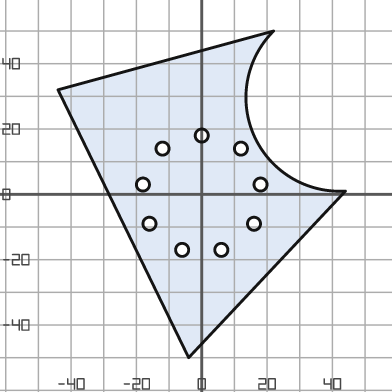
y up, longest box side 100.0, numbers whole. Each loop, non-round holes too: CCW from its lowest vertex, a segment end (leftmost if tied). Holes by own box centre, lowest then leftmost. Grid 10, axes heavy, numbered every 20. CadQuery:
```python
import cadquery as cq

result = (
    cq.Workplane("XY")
    .moveTo(-4.0, -50.0)
    .lineTo(44.0, 1.0)
    .threePointArc((16.0, 18.0), (22.0, 50.0))
    .lineTo(-44.0, 32.0)
    .close()
    .moveTo(-6.0, -17.0)
    .circle(2.0)
    .moveTo(6.0, -17.0)
    .circle(2.0)
    .moveTo(-16.0, -9.0)
    .circle(2.0)
    .moveTo(16.0, -9.0)
    .circle(2.0)
    .moveTo(-18.0, 3.0)
    .circle(2.0)
    .moveTo(18.0, 3.0)
    .circle(2.0)
    .moveTo(-12.0, 14.0)
    .circle(2.0)
    .moveTo(12.0, 14.0)
    .circle(2.0)
    .moveTo(0.0, 18.0)
    .circle(2.0)
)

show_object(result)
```